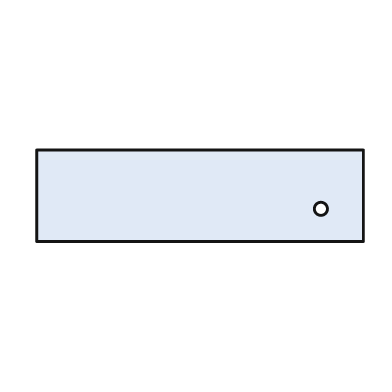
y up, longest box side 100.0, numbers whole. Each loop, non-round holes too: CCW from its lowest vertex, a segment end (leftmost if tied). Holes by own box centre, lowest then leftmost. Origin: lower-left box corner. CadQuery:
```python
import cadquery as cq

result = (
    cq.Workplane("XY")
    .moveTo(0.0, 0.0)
    .lineTo(100.0, 0.0)
    .lineTo(100.0, 28.0)
    .lineTo(0.0, 28.0)
    .close()
    .moveTo(87.0, 10.0)
    .circle(2.0)
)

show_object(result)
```